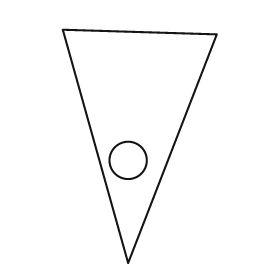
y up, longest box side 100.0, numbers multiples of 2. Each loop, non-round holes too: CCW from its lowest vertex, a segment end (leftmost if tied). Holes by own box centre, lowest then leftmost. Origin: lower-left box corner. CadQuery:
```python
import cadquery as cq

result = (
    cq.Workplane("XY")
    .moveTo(28.0, 0.0)
    .lineTo(66.0, 98.0)
    .lineTo(0.0, 100.0)
    .close()
    .moveTo(28.0, 44.0)
    .circle(8.0)
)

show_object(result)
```